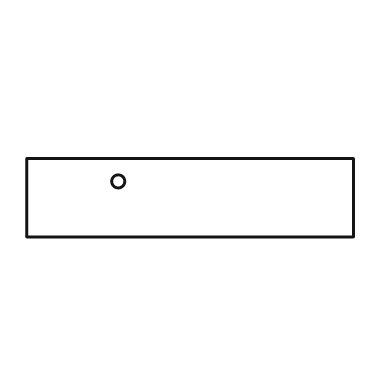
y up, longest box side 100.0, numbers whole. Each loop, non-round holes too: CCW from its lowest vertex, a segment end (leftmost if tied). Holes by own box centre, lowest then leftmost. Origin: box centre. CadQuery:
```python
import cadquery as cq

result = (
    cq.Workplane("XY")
    .moveTo(-50.0, -12.0)
    .lineTo(50.0, -12.0)
    .lineTo(50.0, 12.0)
    .lineTo(-50.0, 12.0)
    .close()
    .moveTo(-22.0, 5.0)
    .circle(2.0)
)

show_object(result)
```